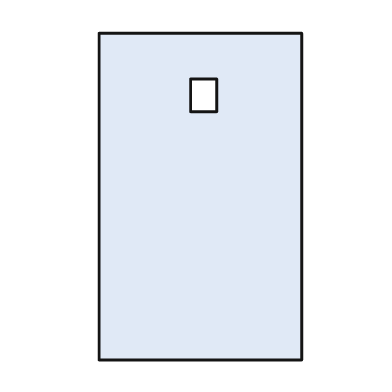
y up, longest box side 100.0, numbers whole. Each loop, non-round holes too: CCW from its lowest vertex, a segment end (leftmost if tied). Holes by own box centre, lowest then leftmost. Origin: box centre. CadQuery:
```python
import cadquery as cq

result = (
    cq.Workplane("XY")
    .moveTo(-31.0, -50.0)
    .lineTo(31.0, -50.0)
    .lineTo(31.0, 50.0)
    .lineTo(-31.0, 50.0)
    .close()
    .moveTo(-3.0, 26.0)
    .lineTo(5.0, 26.0)
    .lineTo(5.0, 36.0)
    .lineTo(-3.0, 36.0)
    .close()
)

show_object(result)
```